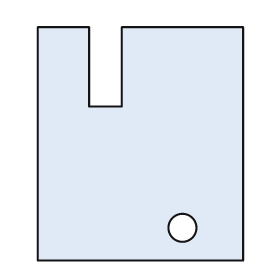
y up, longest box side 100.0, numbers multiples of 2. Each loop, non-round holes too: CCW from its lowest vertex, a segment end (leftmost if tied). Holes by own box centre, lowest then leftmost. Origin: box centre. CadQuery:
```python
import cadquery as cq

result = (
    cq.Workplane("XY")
    .moveTo(-44.0, -50.0)
    .lineTo(44.0, -50.0)
    .lineTo(44.0, 50.0)
    .lineTo(-8.0, 50.0)
    .lineTo(-8.0, 16.0)
    .lineTo(-22.0, 16.0)
    .lineTo(-22.0, 50.0)
    .lineTo(-44.0, 50.0)
    .close()
    .moveTo(18.0, -36.0)
    .circle(6.0)
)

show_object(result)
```